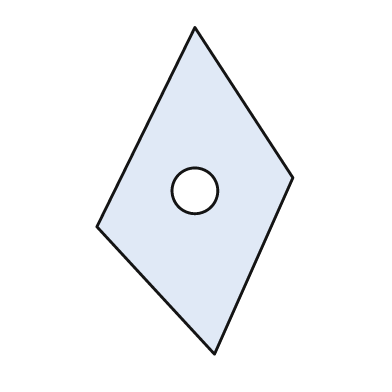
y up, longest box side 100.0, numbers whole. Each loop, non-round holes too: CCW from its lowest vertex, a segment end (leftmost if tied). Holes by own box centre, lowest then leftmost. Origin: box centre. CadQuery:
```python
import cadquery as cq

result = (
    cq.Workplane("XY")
    .moveTo(6.0, -50.0)
    .lineTo(30.0, 4.0)
    .lineTo(0.0, 50.0)
    .lineTo(-30.0, -11.0)
    .close()
    .moveTo(0.0, 0.0)
    .circle(7.0)
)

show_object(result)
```